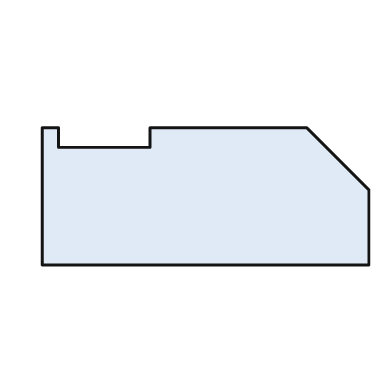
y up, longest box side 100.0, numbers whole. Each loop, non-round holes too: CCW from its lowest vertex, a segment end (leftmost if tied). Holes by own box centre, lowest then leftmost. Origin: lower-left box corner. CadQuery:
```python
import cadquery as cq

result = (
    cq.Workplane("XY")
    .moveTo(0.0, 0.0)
    .lineTo(100.0, 0.0)
    .lineTo(100.0, 23.0)
    .lineTo(81.0, 42.0)
    .lineTo(33.0, 42.0)
    .lineTo(33.0, 36.0)
    .lineTo(5.0, 36.0)
    .lineTo(5.0, 42.0)
    .lineTo(0.0, 42.0)
    .close()
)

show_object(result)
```